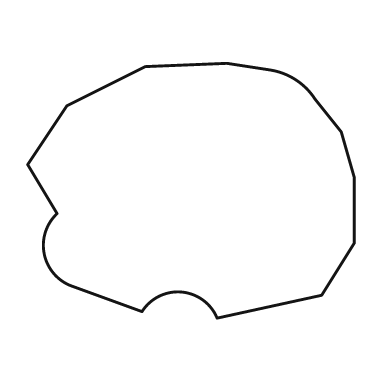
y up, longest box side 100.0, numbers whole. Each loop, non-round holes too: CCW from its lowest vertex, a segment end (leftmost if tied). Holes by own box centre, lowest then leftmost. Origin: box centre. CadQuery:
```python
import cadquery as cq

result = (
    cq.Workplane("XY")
    .moveTo(8.0, -39.0)
    .lineTo(40.0, -32.0)
    .lineTo(50.0, -16.0)
    .lineTo(50.0, 4.0)
    .lineTo(46.0, 18.0)
    .lineTo(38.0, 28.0)
    .threePointArc((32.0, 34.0), (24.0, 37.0))
    .lineTo(11.0, 39.0)
    .lineTo(-14.0, 38.0)
    .lineTo(-38.0, 26.0)
    .lineTo(-50.0, 8.0)
    .lineTo(-41.0, -7.0)
    .threePointArc((-45.0, -19.0), (-37.0, -29.0))
    .lineTo(-15.0, -37.0)
    .threePointArc((-3.0, -31.0), (8.0, -39.0))
    .close()
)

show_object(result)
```